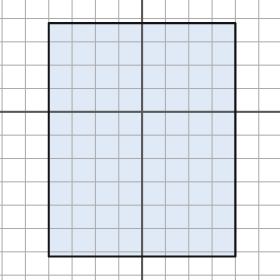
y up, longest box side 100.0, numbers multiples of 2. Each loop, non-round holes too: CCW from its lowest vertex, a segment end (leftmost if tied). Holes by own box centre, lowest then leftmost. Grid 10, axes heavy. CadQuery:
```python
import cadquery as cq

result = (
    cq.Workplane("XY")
    .moveTo(-40.0, -62.0)
    .lineTo(40.0, -62.0)
    .lineTo(40.0, 38.0)
    .lineTo(-40.0, 38.0)
    .close()
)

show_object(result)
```